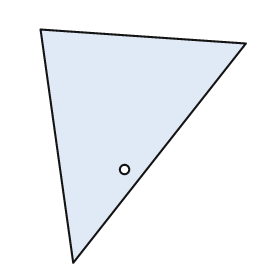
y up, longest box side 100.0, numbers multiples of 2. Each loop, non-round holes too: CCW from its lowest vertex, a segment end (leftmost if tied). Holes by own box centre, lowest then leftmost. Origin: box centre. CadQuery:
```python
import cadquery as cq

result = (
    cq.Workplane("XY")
    .moveTo(-30.0, -50.0)
    .lineTo(44.0, 44.0)
    .lineTo(-44.0, 50.0)
    .close()
    .moveTo(-8.0, -10.0)
    .circle(2.0)
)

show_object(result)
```